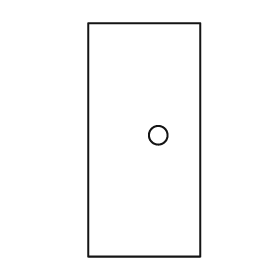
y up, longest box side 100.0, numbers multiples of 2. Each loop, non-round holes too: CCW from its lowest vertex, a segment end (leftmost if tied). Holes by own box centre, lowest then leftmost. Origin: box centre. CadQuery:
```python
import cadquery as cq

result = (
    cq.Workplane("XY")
    .moveTo(-24.0, -50.0)
    .lineTo(24.0, -50.0)
    .lineTo(24.0, 50.0)
    .lineTo(-24.0, 50.0)
    .close()
    .moveTo(6.0, 2.0)
    .circle(4.0)
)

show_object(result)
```